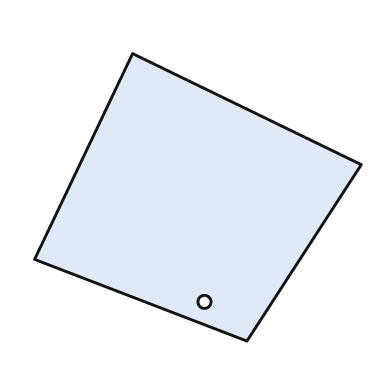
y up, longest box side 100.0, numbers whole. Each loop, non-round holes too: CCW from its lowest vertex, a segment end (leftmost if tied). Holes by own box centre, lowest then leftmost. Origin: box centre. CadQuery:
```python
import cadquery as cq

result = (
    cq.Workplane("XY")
    .moveTo(15.0, -44.0)
    .lineTo(50.0, 10.0)
    .lineTo(-20.0, 44.0)
    .lineTo(-50.0, -19.0)
    .close()
    .moveTo(2.0, -32.0)
    .circle(2.0)
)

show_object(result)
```